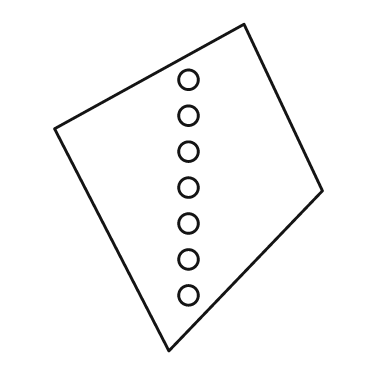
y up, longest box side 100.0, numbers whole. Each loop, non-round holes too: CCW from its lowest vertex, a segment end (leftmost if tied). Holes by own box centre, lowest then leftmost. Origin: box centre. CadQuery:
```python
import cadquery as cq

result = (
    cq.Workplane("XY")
    .moveTo(-6.0, -50.0)
    .lineTo(41.0, -1.0)
    .lineTo(17.0, 50.0)
    .lineTo(-41.0, 18.0)
    .close()
    .moveTo(0.0, -33.0)
    .circle(3.0)
    .moveTo(0.0, -22.0)
    .circle(3.0)
    .moveTo(0.0, -11.0)
    .circle(3.0)
    .moveTo(0.0, 0.0)
    .circle(3.0)
    .moveTo(0.0, 11.0)
    .circle(3.0)
    .moveTo(0.0, 22.0)
    .circle(3.0)
    .moveTo(0.0, 33.0)
    .circle(3.0)
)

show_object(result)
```